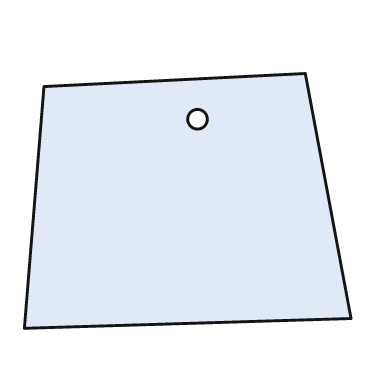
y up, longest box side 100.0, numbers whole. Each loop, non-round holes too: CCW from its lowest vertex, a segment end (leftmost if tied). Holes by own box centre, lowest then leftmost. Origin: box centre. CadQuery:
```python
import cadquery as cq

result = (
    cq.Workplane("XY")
    .moveTo(-50.0, -39.0)
    .lineTo(50.0, -36.0)
    .lineTo(36.0, 39.0)
    .lineTo(-44.0, 35.0)
    .close()
    .moveTo(3.0, 25.0)
    .circle(3.0)
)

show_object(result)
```